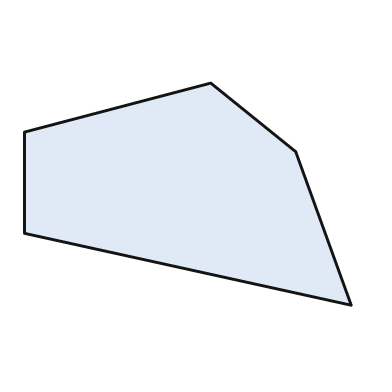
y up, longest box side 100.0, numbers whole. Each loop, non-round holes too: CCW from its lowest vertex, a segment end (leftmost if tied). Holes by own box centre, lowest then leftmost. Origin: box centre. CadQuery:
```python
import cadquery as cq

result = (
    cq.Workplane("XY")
    .moveTo(50.0, -34.0)
    .lineTo(33.0, 13.0)
    .lineTo(7.0, 34.0)
    .lineTo(-50.0, 19.0)
    .lineTo(-50.0, -12.0)
    .close()
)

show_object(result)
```